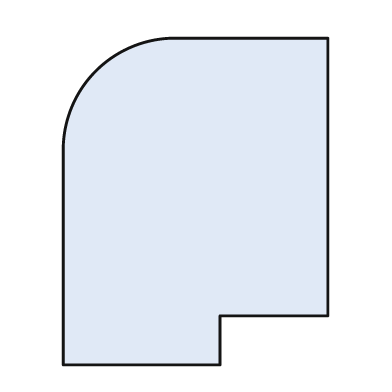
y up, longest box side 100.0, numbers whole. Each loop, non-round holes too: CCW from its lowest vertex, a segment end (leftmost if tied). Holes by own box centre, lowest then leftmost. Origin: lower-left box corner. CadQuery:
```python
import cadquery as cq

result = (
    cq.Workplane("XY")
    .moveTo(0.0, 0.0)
    .lineTo(48.0, 0.0)
    .lineTo(48.0, 15.0)
    .lineTo(81.0, 15.0)
    .lineTo(81.0, 100.0)
    .lineTo(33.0, 100.0)
    .threePointArc((10.0, 90.0), (0.0, 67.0))
    .close()
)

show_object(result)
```